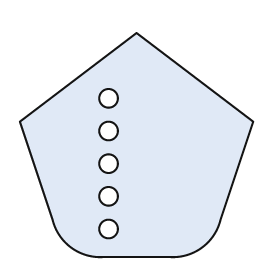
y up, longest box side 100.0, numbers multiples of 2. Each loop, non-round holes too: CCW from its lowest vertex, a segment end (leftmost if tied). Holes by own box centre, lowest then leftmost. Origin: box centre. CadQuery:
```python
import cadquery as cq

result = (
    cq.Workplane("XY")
    .moveTo(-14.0, -48.0)
    .lineTo(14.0, -48.0)
    .threePointArc((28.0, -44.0), (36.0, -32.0))
    .lineTo(50.0, 10.0)
    .lineTo(0.0, 48.0)
    .lineTo(-50.0, 10.0)
    .lineTo(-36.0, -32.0)
    .threePointArc((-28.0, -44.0), (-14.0, -48.0))
    .close()
    .moveTo(-12.0, -36.0)
    .circle(4.0)
    .moveTo(-12.0, -22.0)
    .circle(4.0)
    .moveTo(-12.0, -8.0)
    .circle(4.0)
    .moveTo(-12.0, 6.0)
    .circle(4.0)
    .moveTo(-12.0, 20.0)
    .circle(4.0)
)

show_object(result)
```